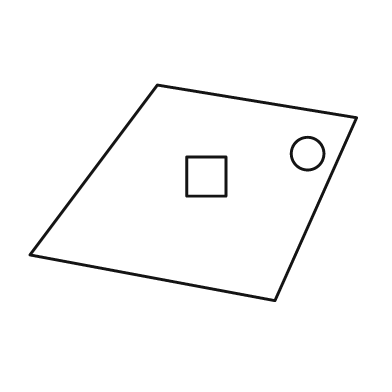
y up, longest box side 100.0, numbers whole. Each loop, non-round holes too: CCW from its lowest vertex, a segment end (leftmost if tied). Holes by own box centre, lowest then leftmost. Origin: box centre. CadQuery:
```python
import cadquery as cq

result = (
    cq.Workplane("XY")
    .moveTo(25.0, -33.0)
    .lineTo(50.0, 23.0)
    .lineTo(-11.0, 33.0)
    .lineTo(-50.0, -19.0)
    .close()
    .moveTo(-2.0, -1.0)
    .lineTo(10.0, -1.0)
    .lineTo(10.0, 11.0)
    .lineTo(-2.0, 11.0)
    .close()
    .moveTo(35.0, 12.0)
    .circle(5.0)
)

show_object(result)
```